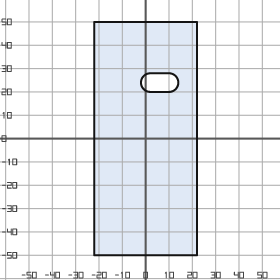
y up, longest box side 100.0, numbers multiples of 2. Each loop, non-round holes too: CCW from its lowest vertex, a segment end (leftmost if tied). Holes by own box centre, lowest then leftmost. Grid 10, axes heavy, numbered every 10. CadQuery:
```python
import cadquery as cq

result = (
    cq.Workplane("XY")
    .moveTo(-22.0, -50.0)
    .lineTo(22.0, -50.0)
    .lineTo(22.0, 50.0)
    .lineTo(-22.0, 50.0)
    .close()
    .moveTo(2.0, 20.0)
    .lineTo(10.0, 20.0)
    .threePointArc((14.0, 24.0), (10.0, 28.0))
    .lineTo(2.0, 28.0)
    .threePointArc((-2.0, 24.0), (2.0, 20.0))
    .close()
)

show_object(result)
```